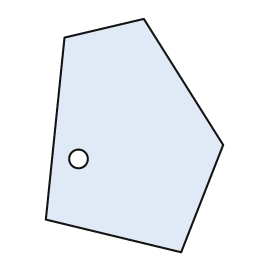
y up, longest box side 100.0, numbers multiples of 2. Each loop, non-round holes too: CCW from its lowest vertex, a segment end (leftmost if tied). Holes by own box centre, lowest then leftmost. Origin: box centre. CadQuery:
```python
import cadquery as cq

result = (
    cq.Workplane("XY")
    .moveTo(20.0, -50.0)
    .lineTo(38.0, -4.0)
    .lineTo(4.0, 50.0)
    .lineTo(-30.0, 42.0)
    .lineTo(-38.0, -36.0)
    .close()
    .moveTo(-24.0, -10.0)
    .circle(4.0)
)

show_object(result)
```